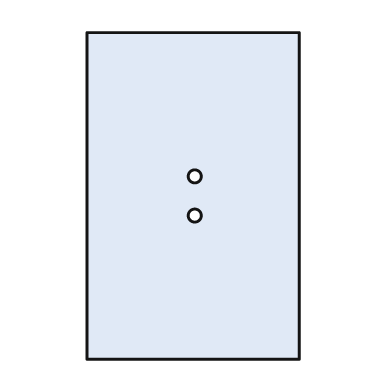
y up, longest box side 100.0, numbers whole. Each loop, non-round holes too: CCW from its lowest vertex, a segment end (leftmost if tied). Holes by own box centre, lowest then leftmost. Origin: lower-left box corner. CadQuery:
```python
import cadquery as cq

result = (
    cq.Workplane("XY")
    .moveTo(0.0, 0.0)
    .lineTo(65.0, 0.0)
    .lineTo(65.0, 100.0)
    .lineTo(0.0, 100.0)
    .close()
    .moveTo(33.0, 44.0)
    .circle(2.0)
    .moveTo(33.0, 56.0)
    .circle(2.0)
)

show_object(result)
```